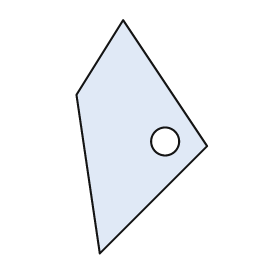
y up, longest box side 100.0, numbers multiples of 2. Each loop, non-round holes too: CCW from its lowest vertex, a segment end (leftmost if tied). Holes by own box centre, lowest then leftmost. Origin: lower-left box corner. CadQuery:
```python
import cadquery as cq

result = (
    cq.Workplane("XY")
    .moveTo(10.0, 0.0)
    .lineTo(56.0, 46.0)
    .lineTo(20.0, 100.0)
    .lineTo(0.0, 68.0)
    .close()
    .moveTo(38.0, 48.0)
    .circle(6.0)
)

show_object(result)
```